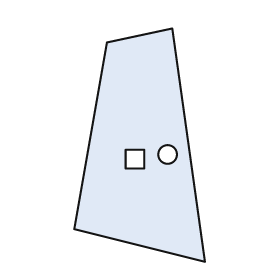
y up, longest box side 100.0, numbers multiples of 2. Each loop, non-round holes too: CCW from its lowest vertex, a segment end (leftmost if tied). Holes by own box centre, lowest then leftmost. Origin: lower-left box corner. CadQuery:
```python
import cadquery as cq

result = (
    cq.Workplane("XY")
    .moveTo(56.0, 0.0)
    .lineTo(42.0, 100.0)
    .lineTo(14.0, 94.0)
    .lineTo(0.0, 14.0)
    .close()
    .moveTo(22.0, 40.0)
    .lineTo(30.0, 40.0)
    .lineTo(30.0, 48.0)
    .lineTo(22.0, 48.0)
    .close()
    .moveTo(40.0, 46.0)
    .circle(4.0)
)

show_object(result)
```